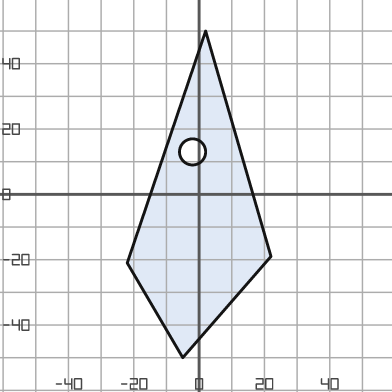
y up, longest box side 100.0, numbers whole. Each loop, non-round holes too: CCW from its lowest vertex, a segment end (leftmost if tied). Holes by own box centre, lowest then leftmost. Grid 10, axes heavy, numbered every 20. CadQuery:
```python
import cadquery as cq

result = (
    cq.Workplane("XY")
    .moveTo(-5.0, -50.0)
    .lineTo(22.0, -19.0)
    .lineTo(2.0, 50.0)
    .lineTo(-22.0, -21.0)
    .close()
    .moveTo(-2.0, 13.0)
    .circle(4.0)
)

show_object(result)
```